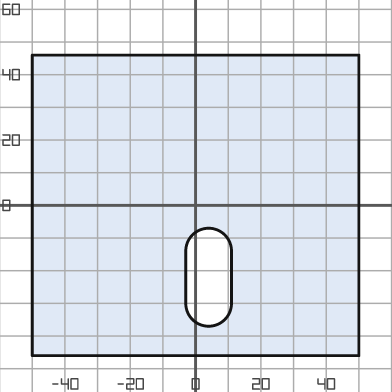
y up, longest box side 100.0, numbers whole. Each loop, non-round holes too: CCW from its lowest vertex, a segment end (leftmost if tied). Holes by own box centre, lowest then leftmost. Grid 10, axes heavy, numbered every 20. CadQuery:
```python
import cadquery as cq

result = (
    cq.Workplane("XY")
    .moveTo(-50.0, -46.0)
    .lineTo(50.0, -46.0)
    .lineTo(50.0, 46.0)
    .lineTo(-50.0, 46.0)
    .close()
    .moveTo(-3.0, -30.0)
    .threePointArc((4.0, -37.0), (11.0, -30.0))
    .lineTo(11.0, -14.0)
    .threePointArc((4.0, -7.0), (-3.0, -14.0))
    .close()
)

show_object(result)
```